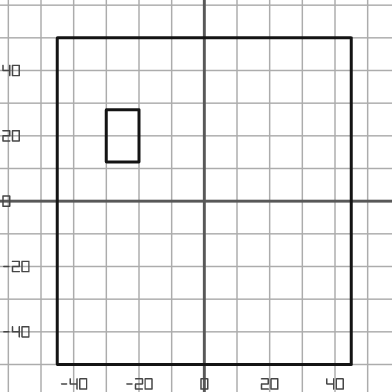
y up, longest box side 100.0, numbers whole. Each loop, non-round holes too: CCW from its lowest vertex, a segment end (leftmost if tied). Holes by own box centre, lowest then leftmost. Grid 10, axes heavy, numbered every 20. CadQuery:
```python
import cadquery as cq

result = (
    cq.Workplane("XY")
    .moveTo(-45.0, -50.0)
    .lineTo(45.0, -50.0)
    .lineTo(45.0, 50.0)
    .lineTo(-45.0, 50.0)
    .close()
    .moveTo(-30.0, 12.0)
    .lineTo(-20.0, 12.0)
    .lineTo(-20.0, 28.0)
    .lineTo(-30.0, 28.0)
    .close()
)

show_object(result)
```